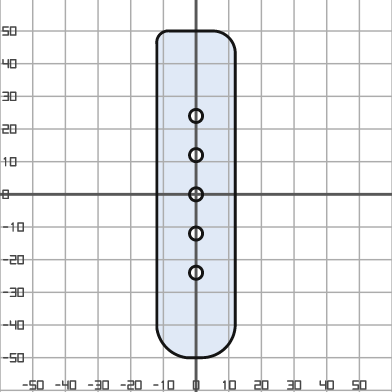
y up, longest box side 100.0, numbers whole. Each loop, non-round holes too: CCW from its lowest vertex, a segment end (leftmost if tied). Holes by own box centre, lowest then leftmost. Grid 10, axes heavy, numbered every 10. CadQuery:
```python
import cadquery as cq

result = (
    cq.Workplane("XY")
    .moveTo(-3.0, -50.0)
    .lineTo(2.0, -50.0)
    .threePointArc((9.0, -47.0), (12.0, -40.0))
    .lineTo(12.0, 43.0)
    .threePointArc((10.0, 48.0), (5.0, 50.0))
    .lineTo(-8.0, 50.0)
    .threePointArc((-11.0, 49.0), (-12.0, 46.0))
    .lineTo(-12.0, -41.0)
    .threePointArc((-9.0, -47.0), (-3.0, -50.0))
    .close()
    .moveTo(0.0, -24.0)
    .circle(2.0)
    .moveTo(0.0, -12.0)
    .circle(2.0)
    .moveTo(0.0, 0.0)
    .circle(2.0)
    .moveTo(0.0, 12.0)
    .circle(2.0)
    .moveTo(0.0, 24.0)
    .circle(2.0)
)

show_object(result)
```